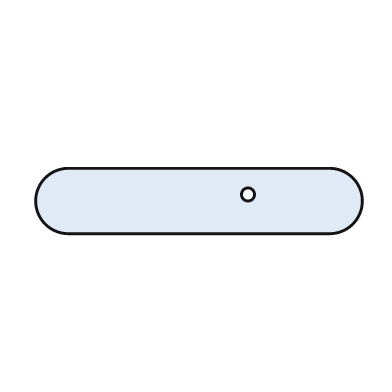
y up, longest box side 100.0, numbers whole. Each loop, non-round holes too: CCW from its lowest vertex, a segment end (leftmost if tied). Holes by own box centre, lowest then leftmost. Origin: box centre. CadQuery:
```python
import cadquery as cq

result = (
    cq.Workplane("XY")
    .moveTo(-40.0, -10.0)
    .lineTo(40.0, -10.0)
    .threePointArc((50.0, 0.0), (40.0, 10.0))
    .lineTo(-40.0, 10.0)
    .threePointArc((-50.0, 0.0), (-40.0, -10.0))
    .close()
    .moveTo(15.0, 2.0)
    .circle(2.0)
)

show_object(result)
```